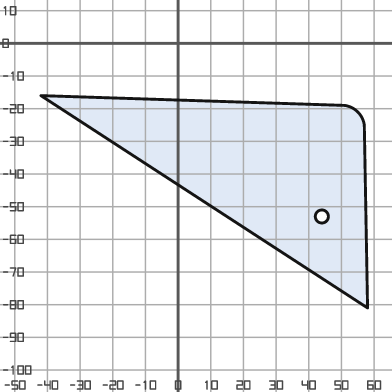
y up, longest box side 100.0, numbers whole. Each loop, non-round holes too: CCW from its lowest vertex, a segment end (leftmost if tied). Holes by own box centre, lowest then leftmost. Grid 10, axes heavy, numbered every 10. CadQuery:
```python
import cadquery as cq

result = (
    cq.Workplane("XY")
    .moveTo(58.0, -81.0)
    .lineTo(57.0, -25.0)
    .threePointArc((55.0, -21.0), (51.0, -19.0))
    .lineTo(-42.0, -16.0)
    .close()
    .moveTo(44.0, -53.0)
    .circle(2.0)
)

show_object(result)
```